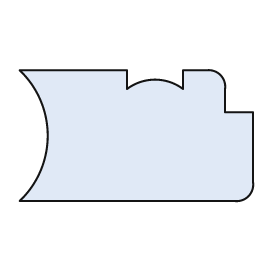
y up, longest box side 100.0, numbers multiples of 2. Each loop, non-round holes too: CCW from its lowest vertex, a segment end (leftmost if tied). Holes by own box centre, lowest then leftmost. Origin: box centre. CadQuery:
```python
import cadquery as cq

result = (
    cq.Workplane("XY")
    .moveTo(-50.0, -28.0)
    .lineTo(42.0, -28.0)
    .threePointArc((48.0, -26.0), (50.0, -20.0))
    .lineTo(50.0, 10.0)
    .lineTo(38.0, 10.0)
    .lineTo(38.0, 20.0)
    .threePointArc((36.0, 26.0), (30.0, 28.0))
    .lineTo(20.0, 28.0)
    .lineTo(20.0, 20.0)
    .threePointArc((8.0, 24.0), (-4.0, 20.0))
    .lineTo(-4.0, 28.0)
    .lineTo(-50.0, 28.0)
    .threePointArc((-38.0, 0.0), (-50.0, -28.0))
    .close()
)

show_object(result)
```